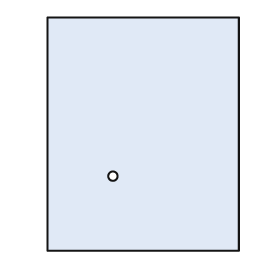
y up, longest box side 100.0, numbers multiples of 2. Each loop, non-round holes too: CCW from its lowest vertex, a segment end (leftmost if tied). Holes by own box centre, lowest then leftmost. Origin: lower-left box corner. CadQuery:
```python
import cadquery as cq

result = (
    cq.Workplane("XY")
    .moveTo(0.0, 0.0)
    .lineTo(82.0, 0.0)
    .lineTo(82.0, 100.0)
    .lineTo(0.0, 100.0)
    .close()
    .moveTo(28.0, 32.0)
    .circle(2.0)
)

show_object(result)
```